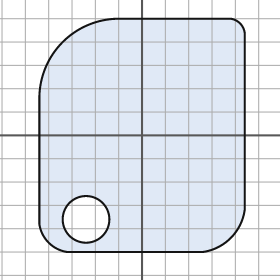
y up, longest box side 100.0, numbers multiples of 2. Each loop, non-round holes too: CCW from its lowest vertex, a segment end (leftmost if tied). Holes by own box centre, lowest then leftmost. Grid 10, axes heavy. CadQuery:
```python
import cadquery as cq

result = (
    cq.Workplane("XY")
    .moveTo(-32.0, -50.0)
    .lineTo(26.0, -50.0)
    .threePointArc((38.0, -44.0), (44.0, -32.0))
    .lineTo(44.0, 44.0)
    .threePointArc((42.0, 48.0), (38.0, 50.0))
    .lineTo(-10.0, 50.0)
    .threePointArc((-34.0, 40.0), (-44.0, 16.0))
    .lineTo(-44.0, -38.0)
    .threePointArc((-40.0, -46.0), (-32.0, -50.0))
    .close()
    .moveTo(-24.0, -36.0)
    .circle(10.0)
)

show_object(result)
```